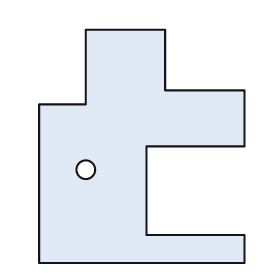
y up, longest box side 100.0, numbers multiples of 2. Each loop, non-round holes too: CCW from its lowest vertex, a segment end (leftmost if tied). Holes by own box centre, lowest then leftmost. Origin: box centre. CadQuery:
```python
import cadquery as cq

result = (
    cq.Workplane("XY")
    .moveTo(-44.0, -50.0)
    .lineTo(44.0, -50.0)
    .lineTo(44.0, -38.0)
    .lineTo(2.0, -38.0)
    .lineTo(2.0, 0.0)
    .lineTo(44.0, 0.0)
    .lineTo(44.0, 24.0)
    .lineTo(10.0, 24.0)
    .lineTo(10.0, 50.0)
    .lineTo(-24.0, 50.0)
    .lineTo(-24.0, 18.0)
    .lineTo(-44.0, 18.0)
    .close()
    .moveTo(-24.0, -10.0)
    .circle(4.0)
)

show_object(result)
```